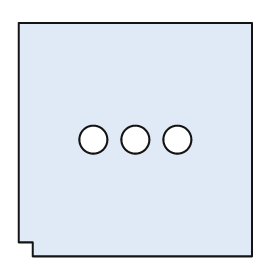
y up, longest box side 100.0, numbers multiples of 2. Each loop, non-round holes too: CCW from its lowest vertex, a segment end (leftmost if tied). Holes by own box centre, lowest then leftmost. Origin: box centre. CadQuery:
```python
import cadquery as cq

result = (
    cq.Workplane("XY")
    .moveTo(-44.0, -50.0)
    .lineTo(50.0, -50.0)
    .lineTo(50.0, 50.0)
    .lineTo(-50.0, 50.0)
    .lineTo(-50.0, -44.0)
    .lineTo(-44.0, -44.0)
    .close()
    .moveTo(-18.0, 0.0)
    .circle(6.0)
    .moveTo(0.0, 0.0)
    .circle(6.0)
    .moveTo(18.0, 0.0)
    .circle(6.0)
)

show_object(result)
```